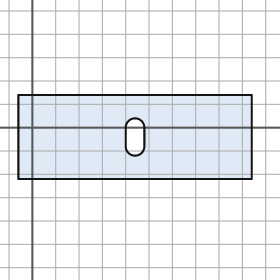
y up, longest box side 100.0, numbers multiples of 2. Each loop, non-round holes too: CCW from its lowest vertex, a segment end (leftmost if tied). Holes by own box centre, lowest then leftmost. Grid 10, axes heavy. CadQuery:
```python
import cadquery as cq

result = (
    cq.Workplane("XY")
    .moveTo(-6.0, -22.0)
    .lineTo(94.0, -22.0)
    .lineTo(94.0, 14.0)
    .lineTo(-6.0, 14.0)
    .close()
    .moveTo(40.0, -8.0)
    .threePointArc((44.0, -12.0), (48.0, -8.0))
    .lineTo(48.0, 0.0)
    .threePointArc((44.0, 4.0), (40.0, 0.0))
    .close()
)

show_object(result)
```